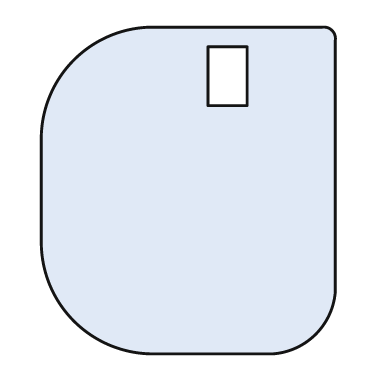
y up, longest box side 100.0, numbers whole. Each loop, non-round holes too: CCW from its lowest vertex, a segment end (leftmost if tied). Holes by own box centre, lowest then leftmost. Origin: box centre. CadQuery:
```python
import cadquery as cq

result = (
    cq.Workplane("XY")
    .moveTo(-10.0, -50.0)
    .lineTo(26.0, -50.0)
    .threePointArc((39.0, -44.0), (45.0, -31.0))
    .lineTo(45.0, 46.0)
    .threePointArc((44.0, 49.0), (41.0, 50.0))
    .lineTo(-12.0, 50.0)
    .threePointArc((-35.0, 40.0), (-45.0, 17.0))
    .lineTo(-45.0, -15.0)
    .threePointArc((-35.0, -40.0), (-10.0, -50.0))
    .close()
    .moveTo(6.0, 26.0)
    .lineTo(18.0, 26.0)
    .lineTo(18.0, 44.0)
    .lineTo(6.0, 44.0)
    .close()
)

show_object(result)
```